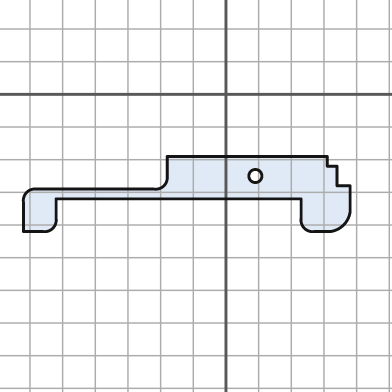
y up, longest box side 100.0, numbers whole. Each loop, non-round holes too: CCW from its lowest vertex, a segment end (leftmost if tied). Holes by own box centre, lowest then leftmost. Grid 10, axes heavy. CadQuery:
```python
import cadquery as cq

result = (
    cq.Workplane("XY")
    .moveTo(-62.0, -42.0)
    .lineTo(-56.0, -42.0)
    .threePointArc((-53.0, -41.0), (-52.0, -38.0))
    .lineTo(-52.0, -32.0)
    .lineTo(23.0, -32.0)
    .lineTo(23.0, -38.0)
    .threePointArc((24.0, -41.0), (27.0, -42.0))
    .lineTo(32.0, -42.0)
    .threePointArc((36.0, -40.0), (38.0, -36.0))
    .lineTo(38.0, -28.0)
    .lineTo(34.0, -28.0)
    .lineTo(34.0, -22.0)
    .lineTo(31.0, -22.0)
    .lineTo(31.0, -19.0)
    .lineTo(-18.0, -19.0)
    .lineTo(-18.0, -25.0)
    .threePointArc((-19.0, -28.0), (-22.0, -29.0))
    .lineTo(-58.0, -29.0)
    .threePointArc((-61.0, -30.0), (-62.0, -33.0))
    .close()
    .moveTo(9.0, -25.0)
    .circle(2.0)
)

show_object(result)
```